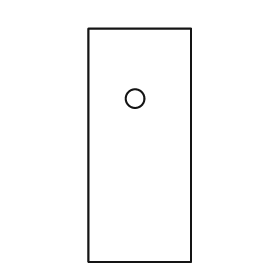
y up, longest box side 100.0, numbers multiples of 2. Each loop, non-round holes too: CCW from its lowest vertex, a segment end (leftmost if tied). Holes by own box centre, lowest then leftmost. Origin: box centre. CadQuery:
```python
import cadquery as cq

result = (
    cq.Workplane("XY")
    .moveTo(-22.0, -50.0)
    .lineTo(22.0, -50.0)
    .lineTo(22.0, 50.0)
    .lineTo(-22.0, 50.0)
    .close()
    .moveTo(-2.0, 20.0)
    .circle(4.0)
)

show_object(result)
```